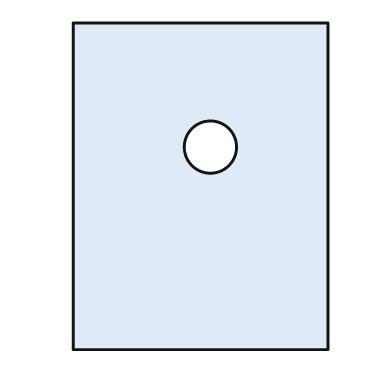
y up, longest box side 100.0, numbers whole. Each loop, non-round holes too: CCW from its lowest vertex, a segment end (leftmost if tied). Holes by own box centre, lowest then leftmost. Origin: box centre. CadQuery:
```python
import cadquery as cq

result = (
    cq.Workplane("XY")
    .moveTo(-39.0, -50.0)
    .lineTo(39.0, -50.0)
    .lineTo(39.0, 50.0)
    .lineTo(-39.0, 50.0)
    .close()
    .moveTo(3.0, 12.0)
    .circle(8.0)
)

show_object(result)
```